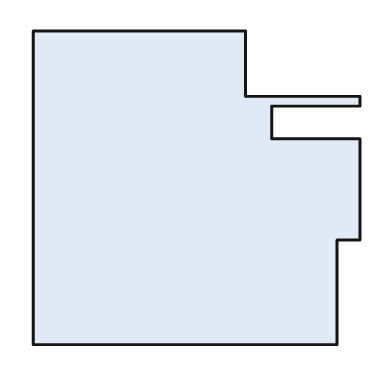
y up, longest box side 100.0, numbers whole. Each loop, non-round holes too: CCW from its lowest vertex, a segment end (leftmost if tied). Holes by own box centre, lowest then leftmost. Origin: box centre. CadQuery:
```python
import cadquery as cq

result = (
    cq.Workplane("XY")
    .moveTo(-50.0, -48.0)
    .lineTo(43.0, -48.0)
    .lineTo(43.0, -16.0)
    .lineTo(50.0, -16.0)
    .lineTo(50.0, 15.0)
    .lineTo(23.0, 15.0)
    .lineTo(23.0, 25.0)
    .lineTo(50.0, 25.0)
    .lineTo(50.0, 28.0)
    .lineTo(15.0, 28.0)
    .lineTo(15.0, 48.0)
    .lineTo(-50.0, 48.0)
    .close()
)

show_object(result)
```